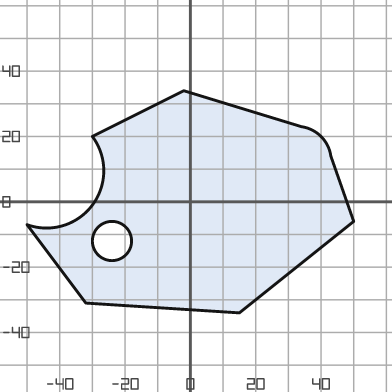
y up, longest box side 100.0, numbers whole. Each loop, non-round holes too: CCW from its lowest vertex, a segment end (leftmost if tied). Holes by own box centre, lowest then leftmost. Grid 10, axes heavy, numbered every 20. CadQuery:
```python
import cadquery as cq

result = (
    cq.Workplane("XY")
    .moveTo(15.0, -34.0)
    .lineTo(50.0, -6.0)
    .lineTo(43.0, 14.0)
    .threePointArc((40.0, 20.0), (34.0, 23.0))
    .lineTo(-2.0, 34.0)
    .lineTo(-30.0, 20.0)
    .threePointArc((-30.0, -1.0), (-50.0, -7.0))
    .lineTo(-32.0, -31.0)
    .close()
    .moveTo(-24.0, -12.0)
    .circle(6.0)
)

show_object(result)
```